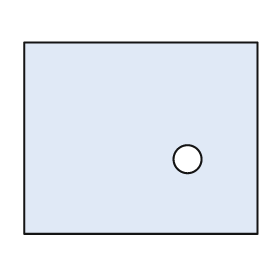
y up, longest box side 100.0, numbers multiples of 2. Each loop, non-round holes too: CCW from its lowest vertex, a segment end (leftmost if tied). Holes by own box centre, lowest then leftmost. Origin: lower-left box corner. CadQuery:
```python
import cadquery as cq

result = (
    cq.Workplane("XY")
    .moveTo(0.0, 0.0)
    .lineTo(100.0, 0.0)
    .lineTo(100.0, 82.0)
    .lineTo(0.0, 82.0)
    .close()
    .moveTo(70.0, 32.0)
    .circle(6.0)
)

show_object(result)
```